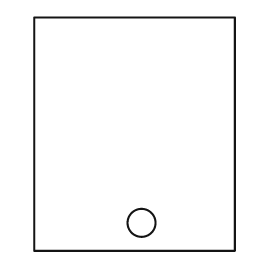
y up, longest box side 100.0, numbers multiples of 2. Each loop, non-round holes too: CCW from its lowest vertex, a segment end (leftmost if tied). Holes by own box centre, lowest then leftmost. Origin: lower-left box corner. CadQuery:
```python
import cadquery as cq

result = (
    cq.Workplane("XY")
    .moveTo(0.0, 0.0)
    .lineTo(86.0, 0.0)
    .lineTo(86.0, 100.0)
    .lineTo(0.0, 100.0)
    .close()
    .moveTo(46.0, 12.0)
    .circle(6.0)
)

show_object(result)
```